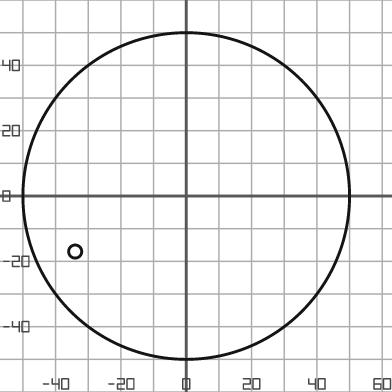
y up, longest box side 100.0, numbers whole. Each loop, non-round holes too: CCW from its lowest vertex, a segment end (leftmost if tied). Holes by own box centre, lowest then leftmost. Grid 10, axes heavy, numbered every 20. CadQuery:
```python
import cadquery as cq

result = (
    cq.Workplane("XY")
    .moveTo(0.0, 0.0)
    .circle(50.0)
    .moveTo(-34.0, -17.0)
    .circle(2.0)
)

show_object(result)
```